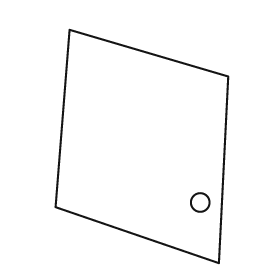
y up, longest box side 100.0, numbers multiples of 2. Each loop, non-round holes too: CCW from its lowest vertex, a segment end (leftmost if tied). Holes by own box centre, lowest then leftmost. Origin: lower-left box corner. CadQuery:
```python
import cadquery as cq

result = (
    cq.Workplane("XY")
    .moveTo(70.0, 0.0)
    .lineTo(74.0, 80.0)
    .lineTo(6.0, 100.0)
    .lineTo(0.0, 24.0)
    .close()
    .moveTo(62.0, 26.0)
    .circle(4.0)
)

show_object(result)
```